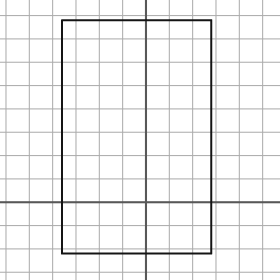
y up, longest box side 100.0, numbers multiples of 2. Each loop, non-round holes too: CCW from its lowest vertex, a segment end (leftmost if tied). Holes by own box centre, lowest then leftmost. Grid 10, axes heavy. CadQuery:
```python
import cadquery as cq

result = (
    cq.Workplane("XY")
    .moveTo(-36.0, -22.0)
    .lineTo(28.0, -22.0)
    .lineTo(28.0, 78.0)
    .lineTo(-36.0, 78.0)
    .close()
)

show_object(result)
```